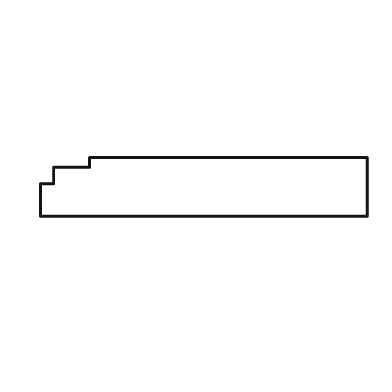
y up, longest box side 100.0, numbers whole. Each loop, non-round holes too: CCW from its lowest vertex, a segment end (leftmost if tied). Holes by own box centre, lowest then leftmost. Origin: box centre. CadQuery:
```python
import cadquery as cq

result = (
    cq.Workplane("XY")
    .moveTo(-50.0, -9.0)
    .lineTo(50.0, -9.0)
    .lineTo(50.0, 9.0)
    .lineTo(-35.0, 9.0)
    .lineTo(-35.0, 6.0)
    .lineTo(-46.0, 6.0)
    .lineTo(-46.0, 1.0)
    .lineTo(-50.0, 1.0)
    .close()
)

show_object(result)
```